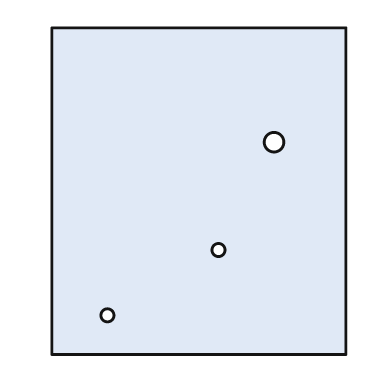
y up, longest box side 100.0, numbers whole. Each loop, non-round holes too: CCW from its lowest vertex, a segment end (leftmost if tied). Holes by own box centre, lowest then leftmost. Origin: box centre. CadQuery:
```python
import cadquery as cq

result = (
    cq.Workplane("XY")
    .moveTo(-45.0, -50.0)
    .lineTo(45.0, -50.0)
    .lineTo(45.0, 50.0)
    .lineTo(-45.0, 50.0)
    .close()
    .moveTo(-28.0, -38.0)
    .circle(2.0)
    .moveTo(6.0, -18.0)
    .circle(2.0)
    .moveTo(23.0, 15.0)
    .circle(3.0)
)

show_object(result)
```